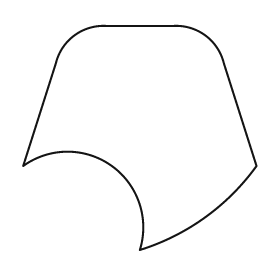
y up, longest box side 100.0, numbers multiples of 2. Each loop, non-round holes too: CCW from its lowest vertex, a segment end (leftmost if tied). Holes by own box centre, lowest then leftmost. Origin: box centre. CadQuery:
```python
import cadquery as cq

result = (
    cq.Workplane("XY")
    .moveTo(0.0, -48.0)
    .threePointArc((28.0, -34.0), (50.0, -12.0))
    .lineTo(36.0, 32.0)
    .threePointArc((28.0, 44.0), (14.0, 48.0))
    .lineTo(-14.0, 48.0)
    .threePointArc((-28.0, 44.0), (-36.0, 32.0))
    .lineTo(-50.0, -12.0)
    .threePointArc((-12.0, -12.0), (0.0, -48.0))
    .close()
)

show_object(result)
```